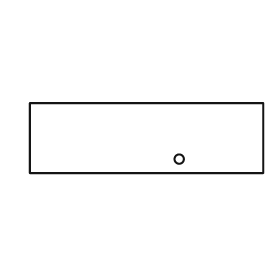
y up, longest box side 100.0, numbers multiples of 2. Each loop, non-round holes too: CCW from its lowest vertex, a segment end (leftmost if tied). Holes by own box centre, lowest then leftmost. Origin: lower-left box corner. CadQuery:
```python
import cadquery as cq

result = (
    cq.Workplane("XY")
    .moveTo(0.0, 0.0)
    .lineTo(100.0, 0.0)
    .lineTo(100.0, 30.0)
    .lineTo(0.0, 30.0)
    .close()
    .moveTo(64.0, 6.0)
    .circle(2.0)
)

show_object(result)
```